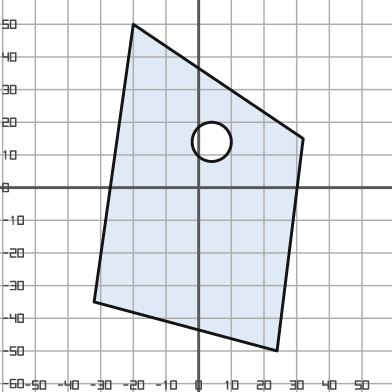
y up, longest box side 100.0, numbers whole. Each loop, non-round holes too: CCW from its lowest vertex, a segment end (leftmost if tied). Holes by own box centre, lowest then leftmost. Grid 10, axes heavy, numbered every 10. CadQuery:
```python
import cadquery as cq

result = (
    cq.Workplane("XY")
    .moveTo(24.0, -50.0)
    .lineTo(32.0, 15.0)
    .lineTo(-20.0, 50.0)
    .lineTo(-32.0, -35.0)
    .close()
    .moveTo(4.0, 14.0)
    .circle(6.0)
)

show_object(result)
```